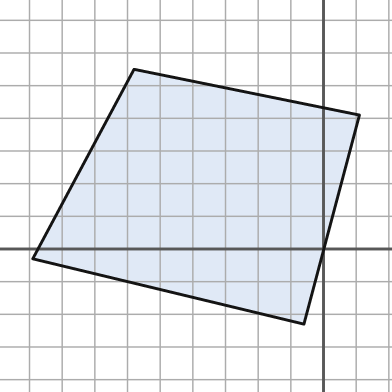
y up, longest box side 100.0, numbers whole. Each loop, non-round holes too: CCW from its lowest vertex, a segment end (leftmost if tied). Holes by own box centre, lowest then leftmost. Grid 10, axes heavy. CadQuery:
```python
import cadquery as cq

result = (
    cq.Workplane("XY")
    .moveTo(-6.0, -23.0)
    .lineTo(11.0, 41.0)
    .lineTo(-58.0, 55.0)
    .lineTo(-89.0, -3.0)
    .close()
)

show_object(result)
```